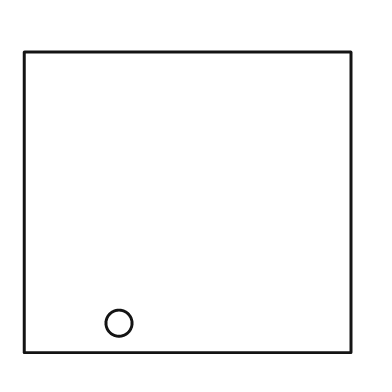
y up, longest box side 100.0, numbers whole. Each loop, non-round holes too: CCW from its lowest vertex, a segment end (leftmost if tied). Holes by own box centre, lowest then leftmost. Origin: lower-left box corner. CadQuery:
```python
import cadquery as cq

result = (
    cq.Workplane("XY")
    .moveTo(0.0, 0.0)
    .lineTo(100.0, 0.0)
    .lineTo(100.0, 92.0)
    .lineTo(0.0, 92.0)
    .close()
    .moveTo(29.0, 9.0)
    .circle(4.0)
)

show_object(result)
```